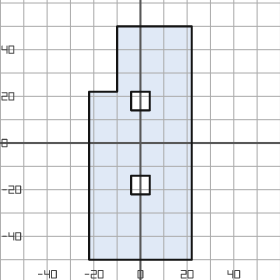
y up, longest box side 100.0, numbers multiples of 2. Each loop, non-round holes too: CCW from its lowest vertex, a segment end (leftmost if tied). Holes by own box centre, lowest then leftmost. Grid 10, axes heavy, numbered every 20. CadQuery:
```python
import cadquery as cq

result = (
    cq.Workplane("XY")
    .moveTo(-22.0, -50.0)
    .lineTo(22.0, -50.0)
    .lineTo(22.0, 50.0)
    .lineTo(-10.0, 50.0)
    .lineTo(-10.0, 22.0)
    .lineTo(-22.0, 22.0)
    .close()
    .moveTo(-4.0, -22.0)
    .lineTo(4.0, -22.0)
    .lineTo(4.0, -14.0)
    .lineTo(-4.0, -14.0)
    .close()
    .moveTo(-4.0, 14.0)
    .lineTo(4.0, 14.0)
    .lineTo(4.0, 22.0)
    .lineTo(-4.0, 22.0)
    .close()
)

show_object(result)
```